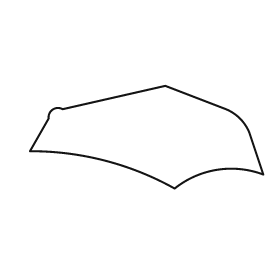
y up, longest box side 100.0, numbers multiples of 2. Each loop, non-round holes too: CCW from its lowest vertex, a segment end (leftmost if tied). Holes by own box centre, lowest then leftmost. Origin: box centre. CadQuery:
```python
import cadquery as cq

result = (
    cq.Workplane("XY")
    .moveTo(12.0, -22.0)
    .threePointArc((30.0, -14.0), (50.0, -16.0))
    .lineTo(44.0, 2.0)
    .threePointArc((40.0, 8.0), (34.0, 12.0))
    .lineTo(8.0, 22.0)
    .lineTo(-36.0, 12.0)
    .threePointArc((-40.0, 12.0), (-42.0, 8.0))
    .lineTo(-50.0, -6.0)
    .threePointArc((-18.0, -10.0), (12.0, -22.0))
    .close()
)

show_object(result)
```